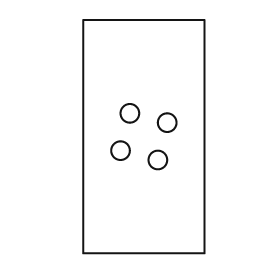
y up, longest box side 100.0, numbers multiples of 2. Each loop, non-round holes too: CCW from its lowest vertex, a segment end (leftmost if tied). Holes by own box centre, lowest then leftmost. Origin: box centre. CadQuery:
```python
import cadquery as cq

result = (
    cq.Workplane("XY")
    .moveTo(-26.0, -50.0)
    .lineTo(26.0, -50.0)
    .lineTo(26.0, 50.0)
    .lineTo(-26.0, 50.0)
    .close()
    .moveTo(6.0, -10.0)
    .circle(4.0)
    .moveTo(-10.0, -6.0)
    .circle(4.0)
    .moveTo(10.0, 6.0)
    .circle(4.0)
    .moveTo(-6.0, 10.0)
    .circle(4.0)
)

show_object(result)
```